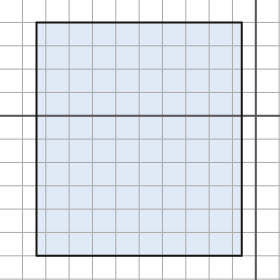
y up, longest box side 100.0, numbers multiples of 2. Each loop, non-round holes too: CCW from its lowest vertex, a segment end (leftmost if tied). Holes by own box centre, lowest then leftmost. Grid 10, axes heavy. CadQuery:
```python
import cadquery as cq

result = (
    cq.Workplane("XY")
    .moveTo(-94.0, -60.0)
    .lineTo(-6.0, -60.0)
    .lineTo(-6.0, 40.0)
    .lineTo(-94.0, 40.0)
    .close()
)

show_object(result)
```